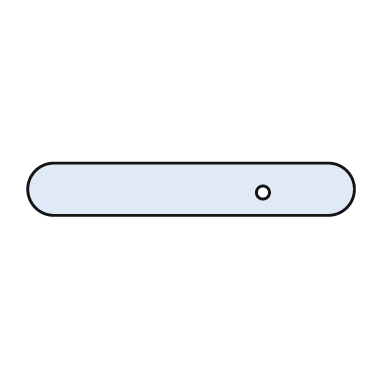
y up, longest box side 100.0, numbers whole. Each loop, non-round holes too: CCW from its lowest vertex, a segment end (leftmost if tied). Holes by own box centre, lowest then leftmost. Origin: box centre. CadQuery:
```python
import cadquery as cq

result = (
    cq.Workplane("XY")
    .moveTo(-42.0, -8.0)
    .lineTo(42.0, -8.0)
    .threePointArc((50.0, 0.0), (42.0, 8.0))
    .lineTo(-42.0, 8.0)
    .threePointArc((-50.0, 0.0), (-42.0, -8.0))
    .close()
    .moveTo(22.0, -1.0)
    .circle(2.0)
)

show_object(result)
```